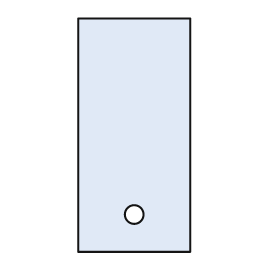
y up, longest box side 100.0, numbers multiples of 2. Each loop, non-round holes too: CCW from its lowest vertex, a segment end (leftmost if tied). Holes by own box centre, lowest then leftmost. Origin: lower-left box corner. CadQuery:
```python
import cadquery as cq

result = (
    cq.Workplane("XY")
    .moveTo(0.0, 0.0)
    .lineTo(48.0, 0.0)
    .lineTo(48.0, 100.0)
    .lineTo(0.0, 100.0)
    .close()
    .moveTo(24.0, 16.0)
    .circle(4.0)
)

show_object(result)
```